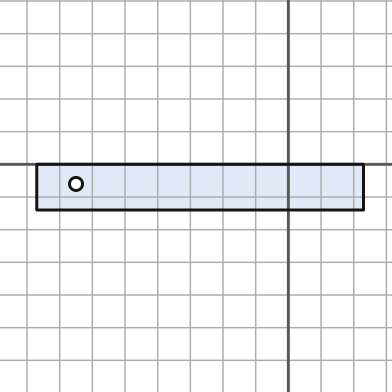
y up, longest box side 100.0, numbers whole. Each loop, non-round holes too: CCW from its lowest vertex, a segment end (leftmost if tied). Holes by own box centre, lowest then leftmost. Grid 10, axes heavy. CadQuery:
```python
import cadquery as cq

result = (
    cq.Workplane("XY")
    .moveTo(-77.0, -14.0)
    .lineTo(23.0, -14.0)
    .lineTo(23.0, 0.0)
    .lineTo(-77.0, 0.0)
    .close()
    .moveTo(-65.0, -6.0)
    .circle(2.0)
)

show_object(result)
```